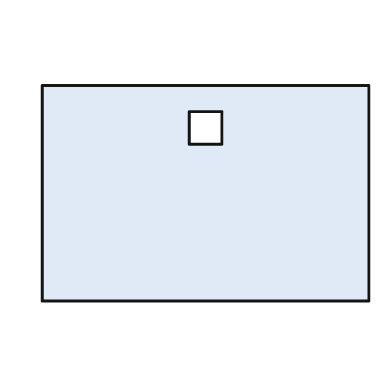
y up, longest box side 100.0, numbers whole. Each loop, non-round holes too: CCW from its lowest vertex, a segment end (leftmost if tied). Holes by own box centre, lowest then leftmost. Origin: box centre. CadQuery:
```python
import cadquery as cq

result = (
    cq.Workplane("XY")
    .moveTo(-50.0, -33.0)
    .lineTo(50.0, -33.0)
    .lineTo(50.0, 33.0)
    .lineTo(-50.0, 33.0)
    .close()
    .moveTo(-5.0, 15.0)
    .lineTo(5.0, 15.0)
    .lineTo(5.0, 25.0)
    .lineTo(-5.0, 25.0)
    .close()
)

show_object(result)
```